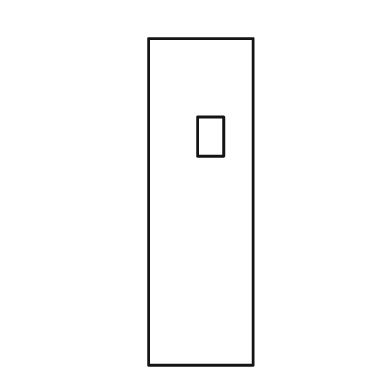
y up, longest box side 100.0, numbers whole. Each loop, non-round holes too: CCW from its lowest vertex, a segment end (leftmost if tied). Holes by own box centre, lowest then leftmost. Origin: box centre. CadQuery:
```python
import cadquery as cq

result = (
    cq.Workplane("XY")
    .moveTo(-16.0, -50.0)
    .lineTo(16.0, -50.0)
    .lineTo(16.0, 50.0)
    .lineTo(-16.0, 50.0)
    .close()
    .moveTo(-1.0, 14.0)
    .lineTo(7.0, 14.0)
    .lineTo(7.0, 26.0)
    .lineTo(-1.0, 26.0)
    .close()
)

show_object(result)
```